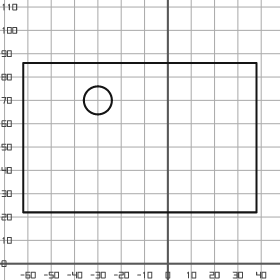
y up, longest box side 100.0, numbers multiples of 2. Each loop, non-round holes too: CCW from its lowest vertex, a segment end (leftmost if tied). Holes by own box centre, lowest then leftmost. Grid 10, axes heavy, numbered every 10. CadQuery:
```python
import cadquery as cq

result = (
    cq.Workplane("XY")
    .moveTo(-62.0, 22.0)
    .lineTo(38.0, 22.0)
    .lineTo(38.0, 86.0)
    .lineTo(-62.0, 86.0)
    .close()
    .moveTo(-30.0, 70.0)
    .circle(6.0)
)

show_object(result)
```